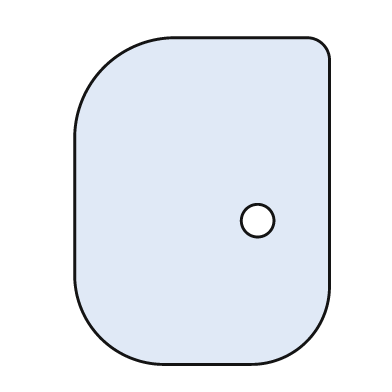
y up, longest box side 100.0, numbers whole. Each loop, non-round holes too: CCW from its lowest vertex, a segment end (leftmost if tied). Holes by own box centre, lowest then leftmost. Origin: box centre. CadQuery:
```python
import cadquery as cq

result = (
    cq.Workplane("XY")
    .moveTo(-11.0, -50.0)
    .lineTo(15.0, -50.0)
    .threePointArc((32.0, -43.0), (39.0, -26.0))
    .lineTo(39.0, 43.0)
    .threePointArc((37.0, 48.0), (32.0, 50.0))
    .lineTo(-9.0, 50.0)
    .threePointArc((-30.0, 41.0), (-39.0, 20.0))
    .lineTo(-39.0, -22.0)
    .threePointArc((-31.0, -42.0), (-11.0, -50.0))
    .close()
    .moveTo(17.0, -6.0)
    .circle(5.0)
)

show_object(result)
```